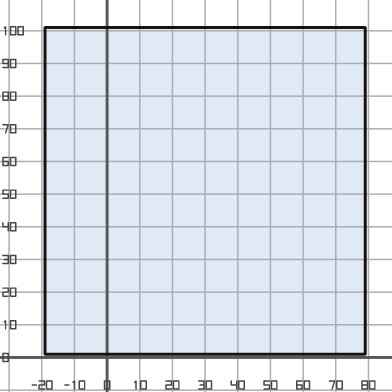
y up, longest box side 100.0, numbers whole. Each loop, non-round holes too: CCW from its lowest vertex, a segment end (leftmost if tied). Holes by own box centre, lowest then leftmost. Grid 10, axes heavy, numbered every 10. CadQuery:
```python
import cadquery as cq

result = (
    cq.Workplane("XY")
    .moveTo(-19.0, 1.0)
    .lineTo(79.0, 1.0)
    .lineTo(79.0, 101.0)
    .lineTo(-19.0, 101.0)
    .close()
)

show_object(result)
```